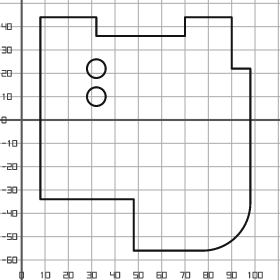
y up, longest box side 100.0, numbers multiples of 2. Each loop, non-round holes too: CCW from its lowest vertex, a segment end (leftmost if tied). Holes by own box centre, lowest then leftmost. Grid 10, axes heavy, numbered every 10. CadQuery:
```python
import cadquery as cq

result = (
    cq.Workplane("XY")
    .moveTo(48.0, -56.0)
    .lineTo(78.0, -56.0)
    .threePointArc((92.0, -50.0), (98.0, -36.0))
    .lineTo(98.0, 22.0)
    .lineTo(90.0, 22.0)
    .lineTo(90.0, 44.0)
    .lineTo(70.0, 44.0)
    .lineTo(70.0, 36.0)
    .lineTo(32.0, 36.0)
    .lineTo(32.0, 44.0)
    .lineTo(8.0, 44.0)
    .lineTo(8.0, -34.0)
    .lineTo(48.0, -34.0)
    .close()
    .moveTo(32.0, 10.0)
    .circle(4.0)
    .moveTo(32.0, 22.0)
    .circle(4.0)
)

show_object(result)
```